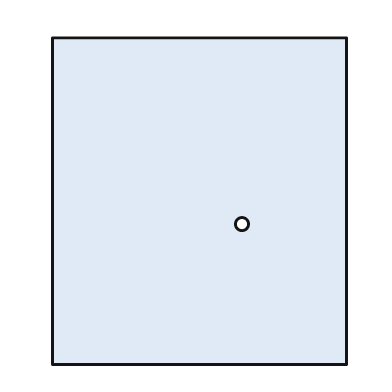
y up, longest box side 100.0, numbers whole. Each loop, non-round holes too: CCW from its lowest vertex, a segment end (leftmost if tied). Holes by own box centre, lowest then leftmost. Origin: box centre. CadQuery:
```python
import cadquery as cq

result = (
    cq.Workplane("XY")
    .moveTo(-45.0, -50.0)
    .lineTo(45.0, -50.0)
    .lineTo(45.0, 50.0)
    .lineTo(-45.0, 50.0)
    .close()
    .moveTo(13.0, -7.0)
    .circle(2.0)
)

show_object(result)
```